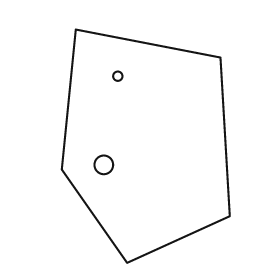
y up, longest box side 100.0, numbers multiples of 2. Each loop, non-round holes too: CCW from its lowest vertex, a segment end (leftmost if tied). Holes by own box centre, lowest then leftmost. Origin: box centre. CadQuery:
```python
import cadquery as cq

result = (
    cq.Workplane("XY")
    .moveTo(-8.0, -50.0)
    .lineTo(36.0, -30.0)
    .lineTo(32.0, 38.0)
    .lineTo(-30.0, 50.0)
    .lineTo(-36.0, -10.0)
    .close()
    .moveTo(-18.0, -8.0)
    .circle(4.0)
    .moveTo(-12.0, 30.0)
    .circle(2.0)
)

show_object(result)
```